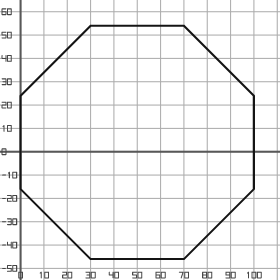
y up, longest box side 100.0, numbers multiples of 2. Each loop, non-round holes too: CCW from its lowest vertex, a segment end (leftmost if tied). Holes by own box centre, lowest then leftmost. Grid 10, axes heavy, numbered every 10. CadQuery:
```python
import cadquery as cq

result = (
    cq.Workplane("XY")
    .moveTo(30.0, -46.0)
    .lineTo(70.0, -46.0)
    .lineTo(100.0, -16.0)
    .lineTo(100.0, 24.0)
    .lineTo(70.0, 54.0)
    .lineTo(30.0, 54.0)
    .lineTo(0.0, 24.0)
    .lineTo(0.0, -16.0)
    .close()
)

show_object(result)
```